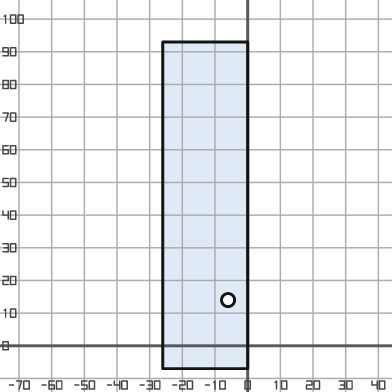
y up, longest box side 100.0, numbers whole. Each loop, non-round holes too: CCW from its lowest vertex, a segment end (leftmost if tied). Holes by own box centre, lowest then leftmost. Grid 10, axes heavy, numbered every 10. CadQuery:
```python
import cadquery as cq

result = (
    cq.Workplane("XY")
    .moveTo(-26.0, -7.0)
    .lineTo(0.0, -7.0)
    .lineTo(0.0, 93.0)
    .lineTo(-26.0, 93.0)
    .close()
    .moveTo(-6.0, 14.0)
    .circle(2.0)
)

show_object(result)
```